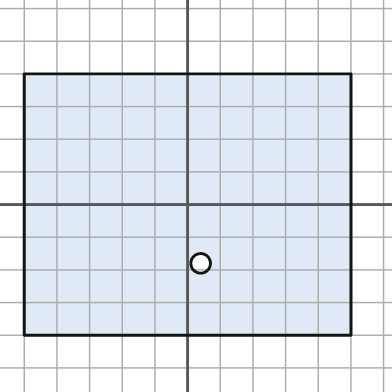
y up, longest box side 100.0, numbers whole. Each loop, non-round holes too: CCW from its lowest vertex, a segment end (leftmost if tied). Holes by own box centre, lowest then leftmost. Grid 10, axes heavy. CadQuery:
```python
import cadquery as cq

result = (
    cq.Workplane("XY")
    .moveTo(-50.0, -40.0)
    .lineTo(50.0, -40.0)
    .lineTo(50.0, 40.0)
    .lineTo(-50.0, 40.0)
    .close()
    .moveTo(4.0, -18.0)
    .circle(3.0)
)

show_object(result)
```